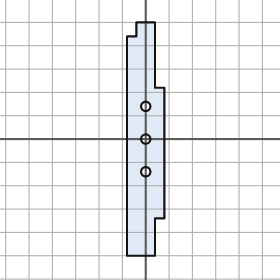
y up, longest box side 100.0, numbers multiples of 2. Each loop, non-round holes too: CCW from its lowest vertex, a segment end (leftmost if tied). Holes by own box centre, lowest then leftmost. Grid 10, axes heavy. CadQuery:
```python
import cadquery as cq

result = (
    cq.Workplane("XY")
    .moveTo(-8.0, -50.0)
    .lineTo(4.0, -50.0)
    .lineTo(4.0, -34.0)
    .lineTo(8.0, -34.0)
    .lineTo(8.0, 22.0)
    .lineTo(4.0, 22.0)
    .lineTo(4.0, 50.0)
    .lineTo(-4.0, 50.0)
    .lineTo(-4.0, 44.0)
    .lineTo(-8.0, 44.0)
    .close()
    .moveTo(0.0, -14.0)
    .circle(2.0)
    .moveTo(0.0, 0.0)
    .circle(2.0)
    .moveTo(0.0, 14.0)
    .circle(2.0)
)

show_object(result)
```